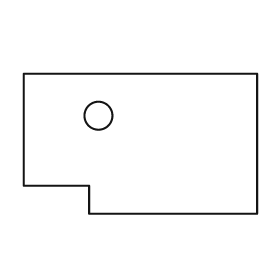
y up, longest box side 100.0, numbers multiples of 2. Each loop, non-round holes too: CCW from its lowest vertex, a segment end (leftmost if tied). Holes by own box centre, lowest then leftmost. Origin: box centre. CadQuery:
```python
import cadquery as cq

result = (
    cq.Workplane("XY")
    .moveTo(-22.0, -30.0)
    .lineTo(50.0, -30.0)
    .lineTo(50.0, 30.0)
    .lineTo(-50.0, 30.0)
    .lineTo(-50.0, -18.0)
    .lineTo(-22.0, -18.0)
    .close()
    .moveTo(-18.0, 12.0)
    .circle(6.0)
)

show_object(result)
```